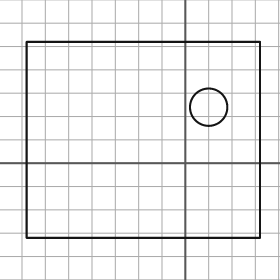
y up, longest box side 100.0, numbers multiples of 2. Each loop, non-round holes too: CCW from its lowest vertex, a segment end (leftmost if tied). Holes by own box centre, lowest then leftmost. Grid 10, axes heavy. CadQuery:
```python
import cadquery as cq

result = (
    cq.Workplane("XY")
    .moveTo(-68.0, -32.0)
    .lineTo(32.0, -32.0)
    .lineTo(32.0, 52.0)
    .lineTo(-68.0, 52.0)
    .close()
    .moveTo(10.0, 24.0)
    .circle(8.0)
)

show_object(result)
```